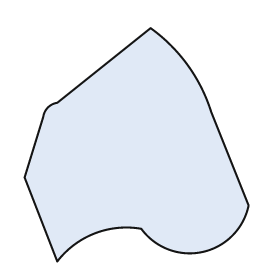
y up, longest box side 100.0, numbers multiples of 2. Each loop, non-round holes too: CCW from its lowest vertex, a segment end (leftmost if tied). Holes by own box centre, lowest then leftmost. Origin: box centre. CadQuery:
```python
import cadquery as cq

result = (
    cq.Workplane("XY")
    .moveTo(-34.0, -50.0)
    .threePointArc((-18.0, -38.0), (2.0, -36.0))
    .threePointArc((28.0, -46.0), (48.0, -26.0))
    .lineTo(32.0, 14.0)
    .threePointArc((22.0, 34.0), (6.0, 50.0))
    .lineTo(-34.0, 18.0)
    .threePointArc((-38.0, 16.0), (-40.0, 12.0))
    .lineTo(-48.0, -14.0)
    .close()
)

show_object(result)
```